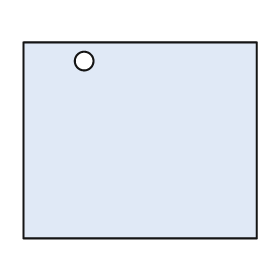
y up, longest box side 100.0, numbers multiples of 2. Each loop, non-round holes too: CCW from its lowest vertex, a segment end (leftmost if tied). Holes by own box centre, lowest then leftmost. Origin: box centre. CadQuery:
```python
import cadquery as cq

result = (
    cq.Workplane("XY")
    .moveTo(-50.0, -42.0)
    .lineTo(50.0, -42.0)
    .lineTo(50.0, 42.0)
    .lineTo(-50.0, 42.0)
    .close()
    .moveTo(-24.0, 34.0)
    .circle(4.0)
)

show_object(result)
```